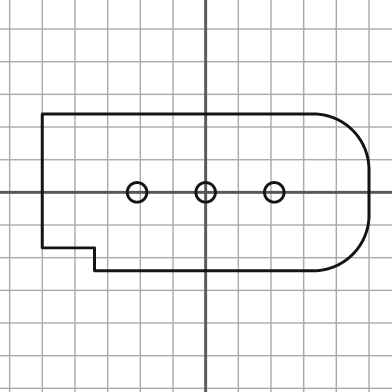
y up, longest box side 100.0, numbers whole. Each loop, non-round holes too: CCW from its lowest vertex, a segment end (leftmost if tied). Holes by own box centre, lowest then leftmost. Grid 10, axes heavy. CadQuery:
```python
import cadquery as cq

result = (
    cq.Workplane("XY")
    .moveTo(-34.0, -24.0)
    .lineTo(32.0, -24.0)
    .threePointArc((45.0, -19.0), (50.0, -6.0))
    .lineTo(50.0, 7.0)
    .threePointArc((45.0, 19.0), (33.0, 24.0))
    .lineTo(-50.0, 24.0)
    .lineTo(-50.0, -17.0)
    .lineTo(-34.0, -17.0)
    .close()
    .moveTo(-21.0, 0.0)
    .circle(3.0)
    .moveTo(0.0, 0.0)
    .circle(3.0)
    .moveTo(21.0, 0.0)
    .circle(3.0)
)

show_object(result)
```